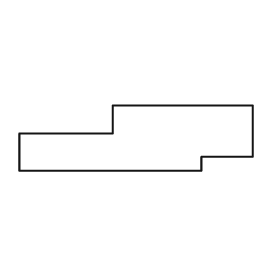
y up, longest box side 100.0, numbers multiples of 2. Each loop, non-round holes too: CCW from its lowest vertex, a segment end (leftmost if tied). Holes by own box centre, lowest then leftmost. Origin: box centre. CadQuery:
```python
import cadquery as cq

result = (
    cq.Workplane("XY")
    .moveTo(-50.0, -14.0)
    .lineTo(28.0, -14.0)
    .lineTo(28.0, -8.0)
    .lineTo(50.0, -8.0)
    .lineTo(50.0, 14.0)
    .lineTo(-10.0, 14.0)
    .lineTo(-10.0, 2.0)
    .lineTo(-50.0, 2.0)
    .close()
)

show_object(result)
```